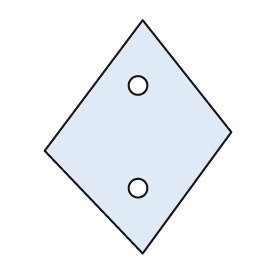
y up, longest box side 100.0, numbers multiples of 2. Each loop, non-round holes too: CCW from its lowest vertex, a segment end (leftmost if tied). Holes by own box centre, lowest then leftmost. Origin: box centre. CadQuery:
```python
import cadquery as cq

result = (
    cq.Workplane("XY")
    .moveTo(2.0, -50.0)
    .lineTo(40.0, 2.0)
    .lineTo(2.0, 50.0)
    .lineTo(-40.0, -6.0)
    .close()
    .moveTo(0.0, -22.0)
    .circle(4.0)
    .moveTo(0.0, 22.0)
    .circle(4.0)
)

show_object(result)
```